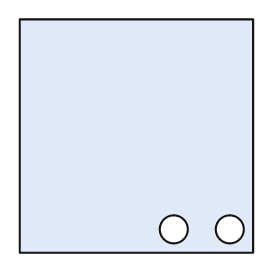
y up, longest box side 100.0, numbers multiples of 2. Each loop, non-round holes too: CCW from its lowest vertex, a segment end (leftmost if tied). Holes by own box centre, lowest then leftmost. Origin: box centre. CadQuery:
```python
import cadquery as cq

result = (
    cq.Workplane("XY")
    .moveTo(-50.0, -50.0)
    .lineTo(50.0, -50.0)
    .lineTo(50.0, 50.0)
    .lineTo(-50.0, 50.0)
    .close()
    .moveTo(16.0, -40.0)
    .circle(6.0)
    .moveTo(40.0, -40.0)
    .circle(6.0)
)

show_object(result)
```